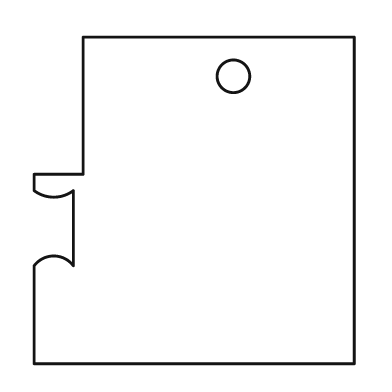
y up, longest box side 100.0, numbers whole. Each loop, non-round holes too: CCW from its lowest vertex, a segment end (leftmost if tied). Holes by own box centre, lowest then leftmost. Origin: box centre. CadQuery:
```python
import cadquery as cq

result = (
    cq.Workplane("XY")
    .moveTo(-49.0, -50.0)
    .lineTo(49.0, -50.0)
    .lineTo(49.0, 50.0)
    .lineTo(-34.0, 50.0)
    .lineTo(-34.0, 8.0)
    .lineTo(-49.0, 8.0)
    .lineTo(-49.0, 3.0)
    .threePointArc((-43.0, 1.0), (-37.0, 3.0))
    .lineTo(-37.0, -20.0)
    .threePointArc((-43.0, -17.0), (-49.0, -20.0))
    .close()
    .moveTo(12.0, 38.0)
    .circle(5.0)
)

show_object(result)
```